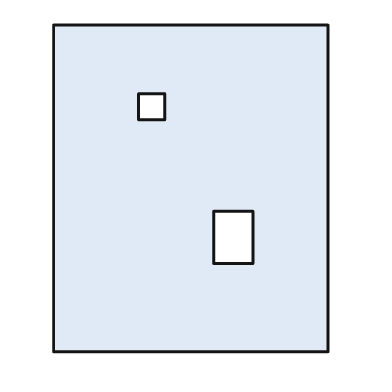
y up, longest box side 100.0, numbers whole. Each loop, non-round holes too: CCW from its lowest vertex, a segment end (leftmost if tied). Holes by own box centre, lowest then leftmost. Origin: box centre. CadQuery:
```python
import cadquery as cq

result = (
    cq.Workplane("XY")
    .moveTo(-42.0, -50.0)
    .lineTo(42.0, -50.0)
    .lineTo(42.0, 50.0)
    .lineTo(-42.0, 50.0)
    .close()
    .moveTo(7.0, -23.0)
    .lineTo(19.0, -23.0)
    .lineTo(19.0, -7.0)
    .lineTo(7.0, -7.0)
    .close()
    .moveTo(-16.0, 21.0)
    .lineTo(-8.0, 21.0)
    .lineTo(-8.0, 29.0)
    .lineTo(-16.0, 29.0)
    .close()
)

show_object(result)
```